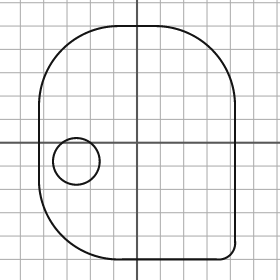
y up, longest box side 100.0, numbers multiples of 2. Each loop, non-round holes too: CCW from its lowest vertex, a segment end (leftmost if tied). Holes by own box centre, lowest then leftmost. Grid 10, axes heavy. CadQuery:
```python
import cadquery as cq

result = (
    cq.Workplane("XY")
    .moveTo(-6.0, -50.0)
    .lineTo(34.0, -50.0)
    .threePointArc((40.0, -48.0), (42.0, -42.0))
    .lineTo(42.0, 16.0)
    .threePointArc((32.0, 40.0), (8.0, 50.0))
    .lineTo(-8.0, 50.0)
    .threePointArc((-32.0, 40.0), (-42.0, 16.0))
    .lineTo(-42.0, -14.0)
    .threePointArc((-32.0, -40.0), (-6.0, -50.0))
    .close()
    .moveTo(-26.0, -8.0)
    .circle(10.0)
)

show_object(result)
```